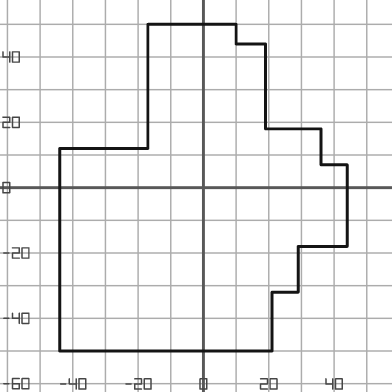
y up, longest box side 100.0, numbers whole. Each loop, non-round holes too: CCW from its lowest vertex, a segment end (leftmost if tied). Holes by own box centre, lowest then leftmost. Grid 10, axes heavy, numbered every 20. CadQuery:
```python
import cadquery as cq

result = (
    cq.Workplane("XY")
    .moveTo(-44.0, -50.0)
    .lineTo(21.0, -50.0)
    .lineTo(21.0, -32.0)
    .lineTo(29.0, -32.0)
    .lineTo(29.0, -18.0)
    .lineTo(44.0, -18.0)
    .lineTo(44.0, 7.0)
    .lineTo(36.0, 7.0)
    .lineTo(36.0, 18.0)
    .lineTo(19.0, 18.0)
    .lineTo(19.0, 44.0)
    .lineTo(10.0, 44.0)
    .lineTo(10.0, 50.0)
    .lineTo(-17.0, 50.0)
    .lineTo(-17.0, 12.0)
    .lineTo(-44.0, 12.0)
    .close()
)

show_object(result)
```